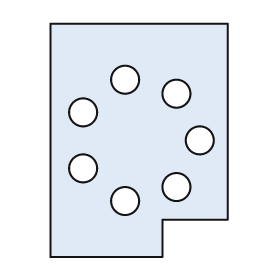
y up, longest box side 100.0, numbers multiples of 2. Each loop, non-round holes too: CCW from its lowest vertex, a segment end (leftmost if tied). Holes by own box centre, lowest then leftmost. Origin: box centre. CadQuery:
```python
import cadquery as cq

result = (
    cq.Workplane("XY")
    .moveTo(-38.0, -50.0)
    .lineTo(10.0, -50.0)
    .lineTo(10.0, -34.0)
    .lineTo(38.0, -34.0)
    .lineTo(38.0, 50.0)
    .lineTo(-38.0, 50.0)
    .close()
    .moveTo(-6.0, -26.0)
    .circle(6.0)
    .moveTo(16.0, -20.0)
    .circle(6.0)
    .moveTo(-24.0, -12.0)
    .circle(6.0)
    .moveTo(26.0, 0.0)
    .circle(6.0)
    .moveTo(-24.0, 12.0)
    .circle(6.0)
    .moveTo(16.0, 20.0)
    .circle(6.0)
    .moveTo(-6.0, 26.0)
    .circle(6.0)
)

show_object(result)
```